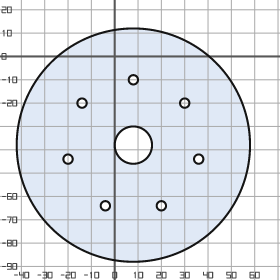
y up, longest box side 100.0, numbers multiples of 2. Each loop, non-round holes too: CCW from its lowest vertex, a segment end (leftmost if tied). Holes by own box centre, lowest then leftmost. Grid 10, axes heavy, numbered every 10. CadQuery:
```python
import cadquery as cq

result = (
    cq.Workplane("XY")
    .moveTo(8.0, -38.0)
    .circle(50.0)
    .moveTo(-4.0, -64.0)
    .circle(2.0)
    .moveTo(20.0, -64.0)
    .circle(2.0)
    .moveTo(-20.0, -44.0)
    .circle(2.0)
    .moveTo(36.0, -44.0)
    .circle(2.0)
    .moveTo(8.0, -38.0)
    .circle(8.0)
    .moveTo(-14.0, -20.0)
    .circle(2.0)
    .moveTo(30.0, -20.0)
    .circle(2.0)
    .moveTo(8.0, -10.0)
    .circle(2.0)
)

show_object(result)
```